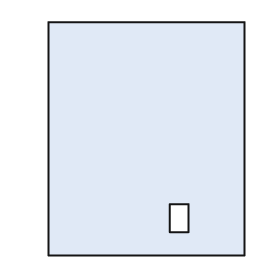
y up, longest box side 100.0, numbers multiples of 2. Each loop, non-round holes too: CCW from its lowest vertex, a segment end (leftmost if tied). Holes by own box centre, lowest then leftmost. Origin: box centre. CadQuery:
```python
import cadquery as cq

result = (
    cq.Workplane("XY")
    .moveTo(-42.0, -50.0)
    .lineTo(42.0, -50.0)
    .lineTo(42.0, 50.0)
    .lineTo(-42.0, 50.0)
    .close()
    .moveTo(10.0, -40.0)
    .lineTo(18.0, -40.0)
    .lineTo(18.0, -28.0)
    .lineTo(10.0, -28.0)
    .close()
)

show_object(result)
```